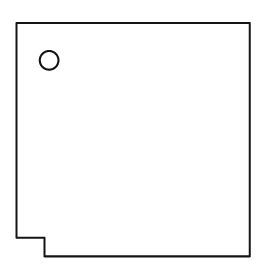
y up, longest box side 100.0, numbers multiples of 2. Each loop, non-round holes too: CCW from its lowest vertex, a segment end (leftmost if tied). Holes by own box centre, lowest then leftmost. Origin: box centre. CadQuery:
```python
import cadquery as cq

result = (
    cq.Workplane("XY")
    .moveTo(-38.0, -50.0)
    .lineTo(50.0, -50.0)
    .lineTo(50.0, 50.0)
    .lineTo(-50.0, 50.0)
    .lineTo(-50.0, -42.0)
    .lineTo(-38.0, -42.0)
    .close()
    .moveTo(-36.0, 34.0)
    .circle(4.0)
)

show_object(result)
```